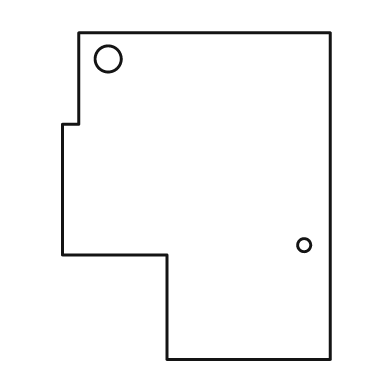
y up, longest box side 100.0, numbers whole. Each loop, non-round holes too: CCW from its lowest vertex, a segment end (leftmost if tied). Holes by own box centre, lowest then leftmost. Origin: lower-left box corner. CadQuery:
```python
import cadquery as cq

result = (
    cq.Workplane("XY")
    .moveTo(32.0, 0.0)
    .lineTo(82.0, 0.0)
    .lineTo(82.0, 100.0)
    .lineTo(5.0, 100.0)
    .lineTo(5.0, 72.0)
    .lineTo(0.0, 72.0)
    .lineTo(0.0, 32.0)
    .lineTo(32.0, 32.0)
    .close()
    .moveTo(74.0, 35.0)
    .circle(2.0)
    .moveTo(14.0, 92.0)
    .circle(4.0)
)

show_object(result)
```